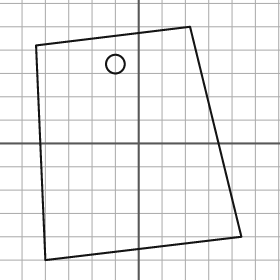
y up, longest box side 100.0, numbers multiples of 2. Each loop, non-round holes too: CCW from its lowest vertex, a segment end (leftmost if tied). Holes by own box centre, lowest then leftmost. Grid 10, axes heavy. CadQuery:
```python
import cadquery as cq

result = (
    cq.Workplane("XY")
    .moveTo(-40.0, -50.0)
    .lineTo(44.0, -40.0)
    .lineTo(22.0, 50.0)
    .lineTo(-44.0, 42.0)
    .close()
    .moveTo(-10.0, 34.0)
    .circle(4.0)
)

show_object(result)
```